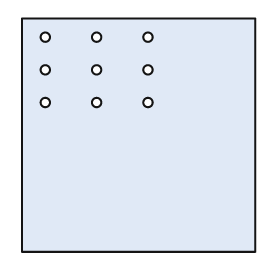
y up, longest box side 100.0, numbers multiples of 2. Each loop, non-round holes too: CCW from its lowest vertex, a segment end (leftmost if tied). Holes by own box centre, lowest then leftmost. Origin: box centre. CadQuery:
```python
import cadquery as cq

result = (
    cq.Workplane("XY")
    .moveTo(-50.0, -50.0)
    .lineTo(50.0, -50.0)
    .lineTo(50.0, 50.0)
    .lineTo(-50.0, 50.0)
    .close()
    .moveTo(-40.0, 14.0)
    .circle(2.0)
    .moveTo(-18.0, 14.0)
    .circle(2.0)
    .moveTo(4.0, 14.0)
    .circle(2.0)
    .moveTo(-40.0, 28.0)
    .circle(2.0)
    .moveTo(-18.0, 28.0)
    .circle(2.0)
    .moveTo(4.0, 28.0)
    .circle(2.0)
    .moveTo(-40.0, 42.0)
    .circle(2.0)
    .moveTo(-18.0, 42.0)
    .circle(2.0)
    .moveTo(4.0, 42.0)
    .circle(2.0)
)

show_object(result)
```